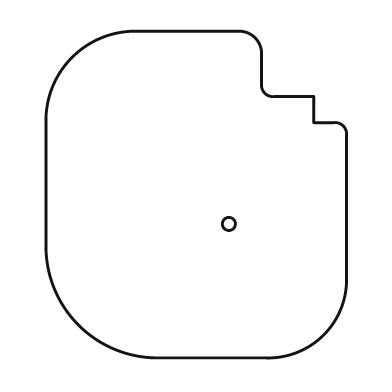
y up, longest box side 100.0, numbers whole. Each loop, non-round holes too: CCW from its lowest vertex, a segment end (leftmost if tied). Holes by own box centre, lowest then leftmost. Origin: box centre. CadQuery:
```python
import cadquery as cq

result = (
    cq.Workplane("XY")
    .moveTo(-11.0, -50.0)
    .lineTo(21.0, -50.0)
    .threePointArc((39.0, -43.0), (46.0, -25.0))
    .lineTo(46.0, 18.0)
    .threePointArc((45.0, 21.0), (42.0, 22.0))
    .lineTo(36.0, 22.0)
    .lineTo(36.0, 30.0)
    .lineTo(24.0, 30.0)
    .threePointArc((21.0, 31.0), (20.0, 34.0))
    .lineTo(20.0, 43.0)
    .threePointArc((18.0, 48.0), (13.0, 50.0))
    .lineTo(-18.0, 50.0)
    .threePointArc((-38.0, 42.0), (-46.0, 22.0))
    .lineTo(-46.0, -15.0)
    .threePointArc((-36.0, -40.0), (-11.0, -50.0))
    .close()
    .moveTo(10.0, -9.0)
    .circle(2.0)
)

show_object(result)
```